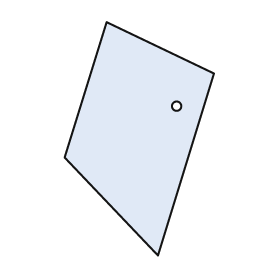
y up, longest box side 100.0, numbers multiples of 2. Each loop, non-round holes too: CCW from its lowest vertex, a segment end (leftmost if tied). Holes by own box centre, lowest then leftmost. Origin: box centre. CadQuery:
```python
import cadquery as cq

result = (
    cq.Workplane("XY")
    .moveTo(8.0, -50.0)
    .lineTo(32.0, 28.0)
    .lineTo(-14.0, 50.0)
    .lineTo(-32.0, -8.0)
    .close()
    .moveTo(16.0, 14.0)
    .circle(2.0)
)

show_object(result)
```